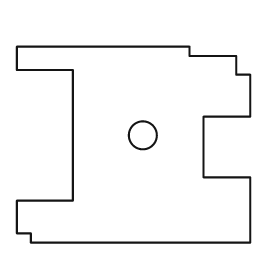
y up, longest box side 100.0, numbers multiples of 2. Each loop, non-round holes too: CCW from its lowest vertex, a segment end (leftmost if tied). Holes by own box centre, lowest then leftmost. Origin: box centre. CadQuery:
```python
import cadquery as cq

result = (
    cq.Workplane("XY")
    .moveTo(-44.0, -42.0)
    .lineTo(50.0, -42.0)
    .lineTo(50.0, -14.0)
    .lineTo(30.0, -14.0)
    .lineTo(30.0, 12.0)
    .lineTo(50.0, 12.0)
    .lineTo(50.0, 30.0)
    .lineTo(44.0, 30.0)
    .lineTo(44.0, 38.0)
    .lineTo(24.0, 38.0)
    .lineTo(24.0, 42.0)
    .lineTo(-50.0, 42.0)
    .lineTo(-50.0, 32.0)
    .lineTo(-26.0, 32.0)
    .lineTo(-26.0, -24.0)
    .lineTo(-50.0, -24.0)
    .lineTo(-50.0, -38.0)
    .lineTo(-44.0, -38.0)
    .close()
    .moveTo(4.0, 4.0)
    .circle(6.0)
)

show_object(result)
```